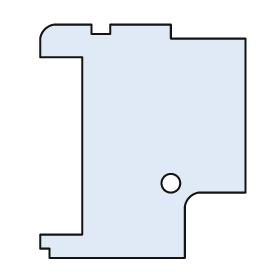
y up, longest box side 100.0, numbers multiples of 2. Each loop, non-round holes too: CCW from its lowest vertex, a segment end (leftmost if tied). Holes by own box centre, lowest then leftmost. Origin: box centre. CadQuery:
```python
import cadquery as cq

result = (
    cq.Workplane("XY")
    .moveTo(-40.0, -50.0)
    .lineTo(18.0, -50.0)
    .lineTo(18.0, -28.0)
    .threePointArc((20.0, -24.0), (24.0, -22.0))
    .lineTo(44.0, -22.0)
    .lineTo(44.0, 44.0)
    .lineTo(12.0, 44.0)
    .lineTo(12.0, 50.0)
    .lineTo(-14.0, 50.0)
    .lineTo(-14.0, 46.0)
    .lineTo(-22.0, 46.0)
    .lineTo(-22.0, 50.0)
    .lineTo(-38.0, 50.0)
    .threePointArc((-42.0, 48.0), (-44.0, 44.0))
    .lineTo(-44.0, 36.0)
    .lineTo(-26.0, 36.0)
    .lineTo(-26.0, -40.0)
    .lineTo(-44.0, -40.0)
    .lineTo(-44.0, -46.0)
    .lineTo(-40.0, -46.0)
    .close()
    .moveTo(12.0, -18.0)
    .circle(4.0)
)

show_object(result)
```